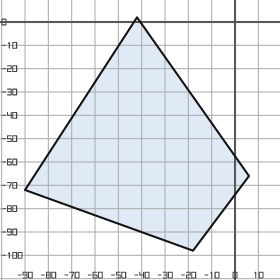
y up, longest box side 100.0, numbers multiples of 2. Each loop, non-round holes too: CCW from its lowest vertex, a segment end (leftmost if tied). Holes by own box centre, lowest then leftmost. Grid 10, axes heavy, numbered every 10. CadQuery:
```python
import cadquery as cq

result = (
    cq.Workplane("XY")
    .moveTo(-18.0, -98.0)
    .lineTo(6.0, -66.0)
    .lineTo(-42.0, 2.0)
    .lineTo(-90.0, -72.0)
    .close()
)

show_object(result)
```